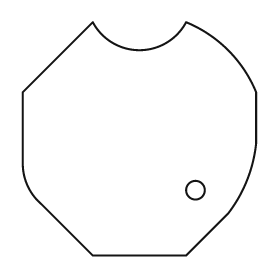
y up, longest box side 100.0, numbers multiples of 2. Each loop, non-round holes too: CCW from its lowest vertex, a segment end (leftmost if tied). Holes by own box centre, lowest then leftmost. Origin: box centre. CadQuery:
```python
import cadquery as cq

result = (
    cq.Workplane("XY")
    .moveTo(-20.0, -50.0)
    .lineTo(20.0, -50.0)
    .lineTo(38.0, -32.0)
    .threePointArc((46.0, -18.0), (50.0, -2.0))
    .lineTo(50.0, 20.0)
    .threePointArc((38.0, 38.0), (20.0, 50.0))
    .threePointArc((0.0, 38.0), (-20.0, 50.0))
    .lineTo(-50.0, 20.0)
    .lineTo(-50.0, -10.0)
    .threePointArc((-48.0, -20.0), (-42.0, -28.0))
    .close()
    .moveTo(24.0, -22.0)
    .circle(4.0)
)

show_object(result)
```